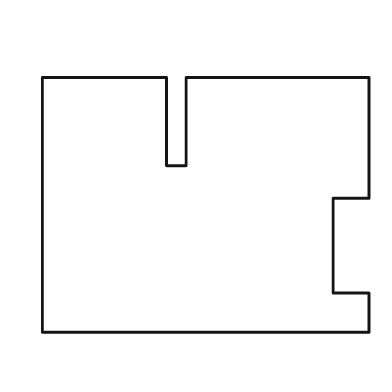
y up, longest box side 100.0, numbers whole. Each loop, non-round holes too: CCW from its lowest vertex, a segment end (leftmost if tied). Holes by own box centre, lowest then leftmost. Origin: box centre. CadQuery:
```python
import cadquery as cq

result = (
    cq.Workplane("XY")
    .moveTo(-50.0, -39.0)
    .lineTo(50.0, -39.0)
    .lineTo(50.0, -27.0)
    .lineTo(39.0, -27.0)
    .lineTo(39.0, 2.0)
    .lineTo(50.0, 2.0)
    .lineTo(50.0, 39.0)
    .lineTo(-6.0, 39.0)
    .lineTo(-6.0, 12.0)
    .lineTo(-12.0, 12.0)
    .lineTo(-12.0, 39.0)
    .lineTo(-50.0, 39.0)
    .close()
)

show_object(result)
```